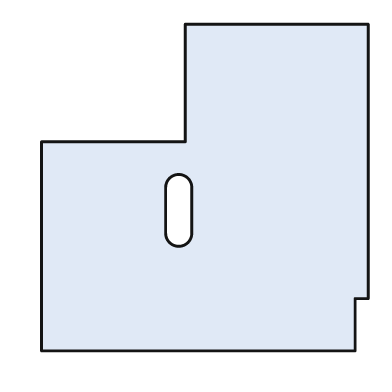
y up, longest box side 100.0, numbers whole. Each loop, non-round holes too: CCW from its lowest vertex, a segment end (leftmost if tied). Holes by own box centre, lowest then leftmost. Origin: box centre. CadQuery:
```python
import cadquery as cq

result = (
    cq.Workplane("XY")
    .moveTo(-50.0, -50.0)
    .lineTo(46.0, -50.0)
    .lineTo(46.0, -34.0)
    .lineTo(50.0, -34.0)
    .lineTo(50.0, 50.0)
    .lineTo(-6.0, 50.0)
    .lineTo(-6.0, 14.0)
    .lineTo(-50.0, 14.0)
    .close()
    .moveTo(-12.0, -14.0)
    .threePointArc((-8.0, -18.0), (-4.0, -14.0))
    .lineTo(-4.0, 0.0)
    .threePointArc((-8.0, 4.0), (-12.0, 0.0))
    .close()
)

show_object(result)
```